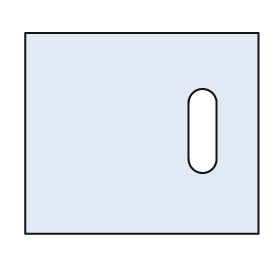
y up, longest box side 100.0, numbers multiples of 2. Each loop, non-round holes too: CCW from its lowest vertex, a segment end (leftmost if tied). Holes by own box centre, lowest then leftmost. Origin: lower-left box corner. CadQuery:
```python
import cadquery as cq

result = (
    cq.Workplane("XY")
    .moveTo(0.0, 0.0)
    .lineTo(100.0, 0.0)
    .lineTo(100.0, 86.0)
    .lineTo(0.0, 86.0)
    .close()
    .moveTo(70.0, 32.0)
    .threePointArc((76.0, 26.0), (82.0, 32.0))
    .lineTo(82.0, 56.0)
    .threePointArc((76.0, 62.0), (70.0, 56.0))
    .close()
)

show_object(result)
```